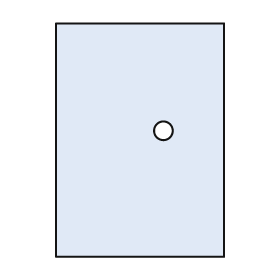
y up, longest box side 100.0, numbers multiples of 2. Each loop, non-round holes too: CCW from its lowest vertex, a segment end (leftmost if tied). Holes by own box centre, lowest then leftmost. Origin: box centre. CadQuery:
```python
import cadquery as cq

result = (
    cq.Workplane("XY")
    .moveTo(-36.0, -50.0)
    .lineTo(36.0, -50.0)
    .lineTo(36.0, 50.0)
    .lineTo(-36.0, 50.0)
    .close()
    .moveTo(10.0, 4.0)
    .circle(4.0)
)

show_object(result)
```